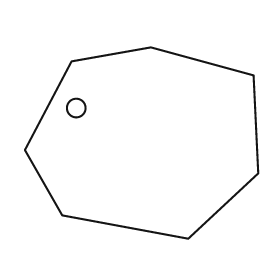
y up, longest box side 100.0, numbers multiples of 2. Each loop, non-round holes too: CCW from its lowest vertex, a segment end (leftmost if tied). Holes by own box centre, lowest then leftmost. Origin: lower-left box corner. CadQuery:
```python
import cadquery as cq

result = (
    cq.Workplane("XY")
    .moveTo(70.0, 0.0)
    .lineTo(100.0, 28.0)
    .lineTo(98.0, 70.0)
    .lineTo(54.0, 82.0)
    .lineTo(20.0, 76.0)
    .lineTo(0.0, 38.0)
    .lineTo(16.0, 10.0)
    .close()
    .moveTo(22.0, 56.0)
    .circle(4.0)
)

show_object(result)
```